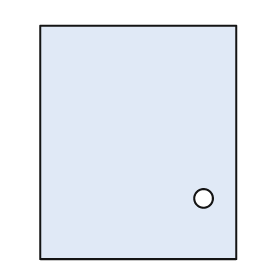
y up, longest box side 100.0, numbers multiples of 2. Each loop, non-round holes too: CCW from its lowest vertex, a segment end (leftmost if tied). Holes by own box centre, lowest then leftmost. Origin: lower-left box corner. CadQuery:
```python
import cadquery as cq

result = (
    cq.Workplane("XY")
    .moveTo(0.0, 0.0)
    .lineTo(84.0, 0.0)
    .lineTo(84.0, 100.0)
    .lineTo(0.0, 100.0)
    .close()
    .moveTo(70.0, 26.0)
    .circle(4.0)
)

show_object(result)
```